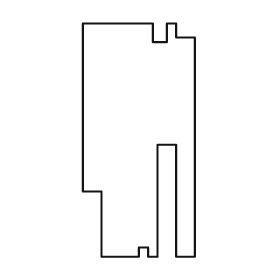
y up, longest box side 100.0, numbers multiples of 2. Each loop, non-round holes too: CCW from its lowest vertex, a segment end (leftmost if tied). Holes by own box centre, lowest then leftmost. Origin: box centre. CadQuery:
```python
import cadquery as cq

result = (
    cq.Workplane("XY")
    .moveTo(-16.0, -50.0)
    .lineTo(0.0, -50.0)
    .lineTo(0.0, -46.0)
    .lineTo(4.0, -46.0)
    .lineTo(4.0, -50.0)
    .lineTo(8.0, -50.0)
    .lineTo(8.0, -2.0)
    .lineTo(16.0, -2.0)
    .lineTo(16.0, -50.0)
    .lineTo(24.0, -50.0)
    .lineTo(24.0, 44.0)
    .lineTo(16.0, 44.0)
    .lineTo(16.0, 50.0)
    .lineTo(12.0, 50.0)
    .lineTo(12.0, 42.0)
    .lineTo(6.0, 42.0)
    .lineTo(6.0, 50.0)
    .lineTo(-24.0, 50.0)
    .lineTo(-24.0, -22.0)
    .lineTo(-16.0, -22.0)
    .close()
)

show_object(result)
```